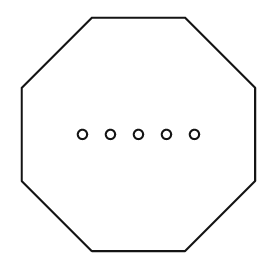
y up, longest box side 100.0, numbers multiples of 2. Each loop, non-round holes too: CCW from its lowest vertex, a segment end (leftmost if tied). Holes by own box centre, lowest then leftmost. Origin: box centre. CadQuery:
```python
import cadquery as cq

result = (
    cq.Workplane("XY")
    .moveTo(-20.0, -50.0)
    .lineTo(20.0, -50.0)
    .lineTo(50.0, -20.0)
    .lineTo(50.0, 20.0)
    .lineTo(20.0, 50.0)
    .lineTo(-20.0, 50.0)
    .lineTo(-50.0, 20.0)
    .lineTo(-50.0, -20.0)
    .close()
    .moveTo(-24.0, 0.0)
    .circle(2.0)
    .moveTo(-12.0, 0.0)
    .circle(2.0)
    .moveTo(0.0, 0.0)
    .circle(2.0)
    .moveTo(12.0, 0.0)
    .circle(2.0)
    .moveTo(24.0, 0.0)
    .circle(2.0)
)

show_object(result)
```